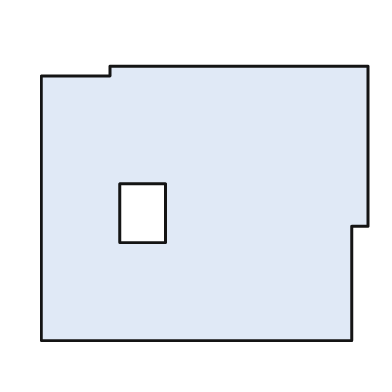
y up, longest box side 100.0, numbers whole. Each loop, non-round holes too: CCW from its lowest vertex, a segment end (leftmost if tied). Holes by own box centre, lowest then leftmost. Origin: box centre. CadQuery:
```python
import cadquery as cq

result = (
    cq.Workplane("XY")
    .moveTo(-50.0, -42.0)
    .lineTo(45.0, -42.0)
    .lineTo(45.0, -7.0)
    .lineTo(50.0, -7.0)
    .lineTo(50.0, 42.0)
    .lineTo(-29.0, 42.0)
    .lineTo(-29.0, 39.0)
    .lineTo(-50.0, 39.0)
    .close()
    .moveTo(-26.0, -12.0)
    .lineTo(-12.0, -12.0)
    .lineTo(-12.0, 6.0)
    .lineTo(-26.0, 6.0)
    .close()
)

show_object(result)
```